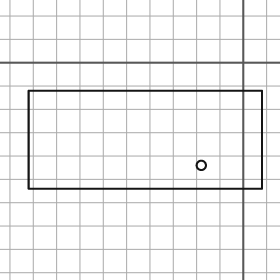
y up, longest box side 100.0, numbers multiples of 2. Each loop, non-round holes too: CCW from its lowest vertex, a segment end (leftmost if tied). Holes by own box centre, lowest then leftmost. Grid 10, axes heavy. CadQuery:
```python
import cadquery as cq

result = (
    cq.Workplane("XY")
    .moveTo(-92.0, -54.0)
    .lineTo(8.0, -54.0)
    .lineTo(8.0, -12.0)
    .lineTo(-92.0, -12.0)
    .close()
    .moveTo(-18.0, -44.0)
    .circle(2.0)
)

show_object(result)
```